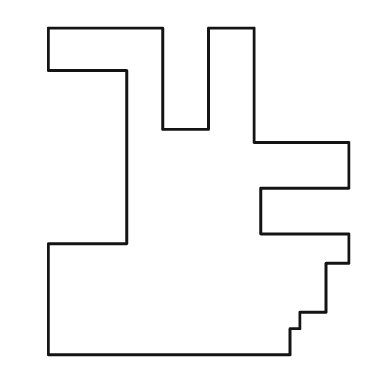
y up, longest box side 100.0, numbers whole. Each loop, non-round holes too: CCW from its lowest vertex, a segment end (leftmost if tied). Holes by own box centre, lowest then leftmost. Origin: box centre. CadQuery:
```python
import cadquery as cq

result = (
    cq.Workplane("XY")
    .moveTo(-46.0, -50.0)
    .lineTo(28.0, -50.0)
    .lineTo(28.0, -42.0)
    .lineTo(31.0, -42.0)
    .lineTo(31.0, -37.0)
    .lineTo(39.0, -37.0)
    .lineTo(39.0, -22.0)
    .lineTo(46.0, -22.0)
    .lineTo(46.0, -13.0)
    .lineTo(19.0, -13.0)
    .lineTo(19.0, 1.0)
    .lineTo(46.0, 1.0)
    .lineTo(46.0, 15.0)
    .lineTo(17.0, 15.0)
    .lineTo(17.0, 50.0)
    .lineTo(3.0, 50.0)
    .lineTo(3.0, 19.0)
    .lineTo(-11.0, 19.0)
    .lineTo(-11.0, 50.0)
    .lineTo(-46.0, 50.0)
    .lineTo(-46.0, 37.0)
    .lineTo(-22.0, 37.0)
    .lineTo(-22.0, -16.0)
    .lineTo(-46.0, -16.0)
    .close()
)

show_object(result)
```